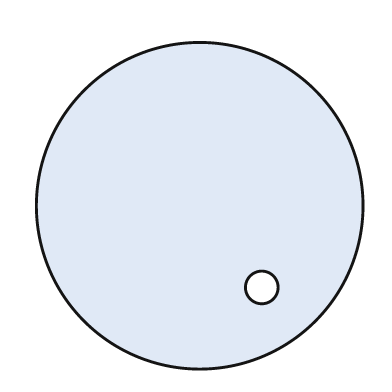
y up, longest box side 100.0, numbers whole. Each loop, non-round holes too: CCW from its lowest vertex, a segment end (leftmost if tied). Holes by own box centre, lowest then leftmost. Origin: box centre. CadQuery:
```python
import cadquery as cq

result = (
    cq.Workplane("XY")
    .moveTo(0.0, 0.0)
    .circle(50.0)
    .moveTo(19.0, -25.0)
    .circle(5.0)
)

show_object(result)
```